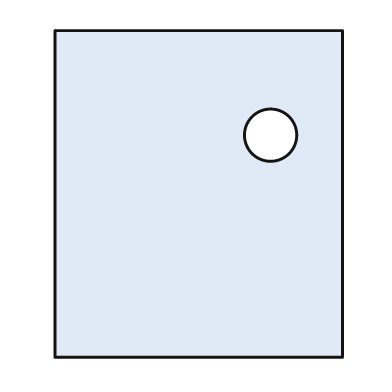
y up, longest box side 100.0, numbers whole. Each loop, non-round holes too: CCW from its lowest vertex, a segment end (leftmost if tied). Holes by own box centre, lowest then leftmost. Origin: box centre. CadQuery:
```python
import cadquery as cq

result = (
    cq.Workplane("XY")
    .moveTo(-44.0, -50.0)
    .lineTo(44.0, -50.0)
    .lineTo(44.0, 50.0)
    .lineTo(-44.0, 50.0)
    .close()
    .moveTo(22.0, 18.0)
    .circle(8.0)
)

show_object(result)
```